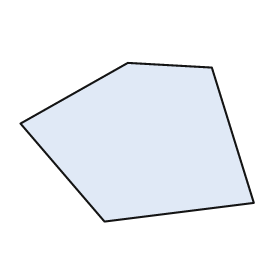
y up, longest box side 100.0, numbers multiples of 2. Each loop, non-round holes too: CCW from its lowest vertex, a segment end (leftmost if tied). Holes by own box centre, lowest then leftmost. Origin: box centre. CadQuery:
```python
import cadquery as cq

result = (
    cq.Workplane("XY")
    .moveTo(-14.0, -34.0)
    .lineTo(50.0, -26.0)
    .lineTo(32.0, 32.0)
    .lineTo(-4.0, 34.0)
    .lineTo(-50.0, 8.0)
    .close()
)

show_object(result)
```